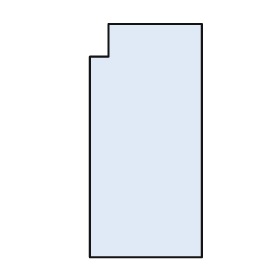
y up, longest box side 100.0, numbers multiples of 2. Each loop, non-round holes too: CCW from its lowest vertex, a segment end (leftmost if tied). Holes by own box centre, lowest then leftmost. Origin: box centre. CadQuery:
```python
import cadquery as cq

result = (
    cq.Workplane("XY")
    .moveTo(-24.0, -50.0)
    .lineTo(24.0, -50.0)
    .lineTo(24.0, 50.0)
    .lineTo(-16.0, 50.0)
    .lineTo(-16.0, 36.0)
    .lineTo(-24.0, 36.0)
    .close()
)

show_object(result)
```